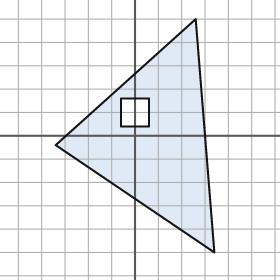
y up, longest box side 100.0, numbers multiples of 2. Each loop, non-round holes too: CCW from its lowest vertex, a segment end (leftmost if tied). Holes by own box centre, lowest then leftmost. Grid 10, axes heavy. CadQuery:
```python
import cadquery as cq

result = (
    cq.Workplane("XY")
    .moveTo(34.0, -50.0)
    .lineTo(26.0, 50.0)
    .lineTo(-34.0, -4.0)
    .close()
    .moveTo(-6.0, 4.0)
    .lineTo(6.0, 4.0)
    .lineTo(6.0, 16.0)
    .lineTo(-6.0, 16.0)
    .close()
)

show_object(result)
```